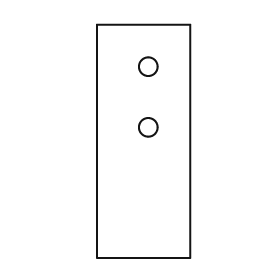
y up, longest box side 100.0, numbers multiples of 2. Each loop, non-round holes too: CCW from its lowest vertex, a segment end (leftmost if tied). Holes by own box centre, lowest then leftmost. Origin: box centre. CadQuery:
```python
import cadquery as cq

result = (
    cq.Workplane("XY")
    .moveTo(-20.0, -50.0)
    .lineTo(20.0, -50.0)
    .lineTo(20.0, 50.0)
    .lineTo(-20.0, 50.0)
    .close()
    .moveTo(2.0, 6.0)
    .circle(4.0)
    .moveTo(2.0, 32.0)
    .circle(4.0)
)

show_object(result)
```